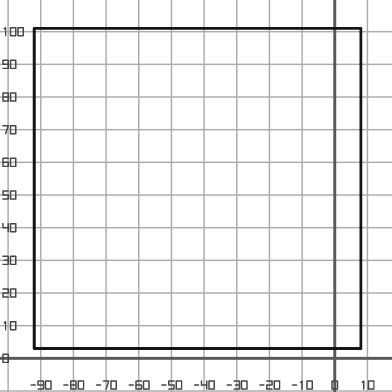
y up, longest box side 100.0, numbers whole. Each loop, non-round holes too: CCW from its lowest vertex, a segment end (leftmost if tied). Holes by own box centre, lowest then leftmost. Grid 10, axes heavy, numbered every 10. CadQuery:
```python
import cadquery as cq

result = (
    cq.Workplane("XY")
    .moveTo(-92.0, 3.0)
    .lineTo(8.0, 3.0)
    .lineTo(8.0, 101.0)
    .lineTo(-92.0, 101.0)
    .close()
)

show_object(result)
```